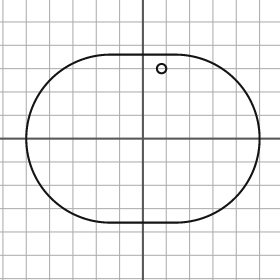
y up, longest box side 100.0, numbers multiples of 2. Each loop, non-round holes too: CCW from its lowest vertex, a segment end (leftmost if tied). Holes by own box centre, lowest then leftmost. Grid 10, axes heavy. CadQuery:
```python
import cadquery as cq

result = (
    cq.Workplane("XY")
    .moveTo(-14.0, -36.0)
    .lineTo(14.0, -36.0)
    .threePointArc((50.0, 0.0), (14.0, 36.0))
    .lineTo(-14.0, 36.0)
    .threePointArc((-50.0, 0.0), (-14.0, -36.0))
    .close()
    .moveTo(8.0, 30.0)
    .circle(2.0)
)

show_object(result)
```